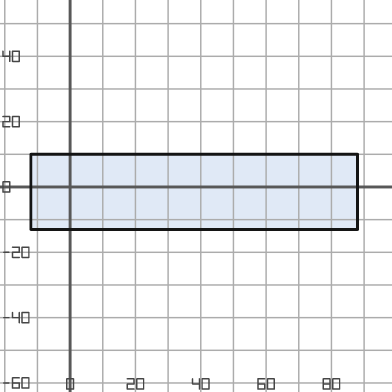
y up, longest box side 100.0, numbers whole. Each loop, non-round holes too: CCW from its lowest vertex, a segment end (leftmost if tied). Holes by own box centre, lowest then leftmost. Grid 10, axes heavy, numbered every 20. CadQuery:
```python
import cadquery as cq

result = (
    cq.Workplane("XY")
    .moveTo(-12.0, -13.0)
    .lineTo(88.0, -13.0)
    .lineTo(88.0, 10.0)
    .lineTo(-12.0, 10.0)
    .close()
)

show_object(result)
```